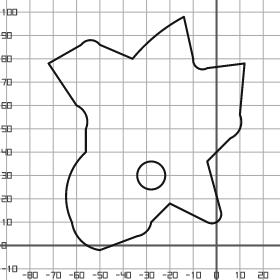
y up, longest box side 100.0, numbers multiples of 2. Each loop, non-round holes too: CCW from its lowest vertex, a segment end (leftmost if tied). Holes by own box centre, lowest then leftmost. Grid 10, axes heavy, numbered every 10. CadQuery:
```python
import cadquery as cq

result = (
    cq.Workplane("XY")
    .moveTo(-50.0, -2.0)
    .lineTo(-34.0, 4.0)
    .threePointArc((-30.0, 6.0), (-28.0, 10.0))
    .lineTo(-20.0, 18.0)
    .lineTo(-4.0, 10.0)
    .threePointArc((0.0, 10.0), (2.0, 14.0))
    .lineTo(-4.0, 36.0)
    .lineTo(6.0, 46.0)
    .threePointArc((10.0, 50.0), (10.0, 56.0))
    .lineTo(12.0, 78.0)
    .lineTo(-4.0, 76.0)
    .threePointArc((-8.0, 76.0), (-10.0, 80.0))
    .lineTo(-14.0, 98.0)
    .threePointArc((-26.0, 90.0), (-36.0, 80.0))
    .lineTo(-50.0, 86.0)
    .threePointArc((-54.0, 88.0), (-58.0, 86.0))
    .lineTo(-72.0, 78.0)
    .lineTo(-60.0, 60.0)
    .threePointArc((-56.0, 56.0), (-56.0, 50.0))
    .lineTo(-56.0, 40.0)
    .threePointArc((-64.0, 26.0), (-62.0, 10.0))
    .threePointArc((-58.0, 2.0), (-50.0, -2.0))
    .close()
    .moveTo(-28.0, 30.0)
    .circle(6.0)
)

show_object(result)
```